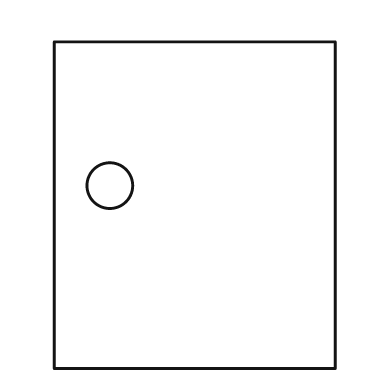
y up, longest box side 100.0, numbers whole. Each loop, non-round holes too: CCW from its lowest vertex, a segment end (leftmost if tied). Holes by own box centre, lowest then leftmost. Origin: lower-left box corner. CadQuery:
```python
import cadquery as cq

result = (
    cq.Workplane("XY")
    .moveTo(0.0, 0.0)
    .lineTo(86.0, 0.0)
    .lineTo(86.0, 100.0)
    .lineTo(0.0, 100.0)
    .close()
    .moveTo(17.0, 56.0)
    .circle(7.0)
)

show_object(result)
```